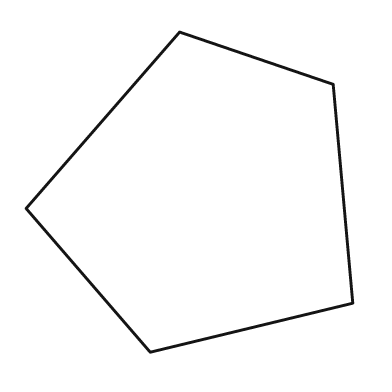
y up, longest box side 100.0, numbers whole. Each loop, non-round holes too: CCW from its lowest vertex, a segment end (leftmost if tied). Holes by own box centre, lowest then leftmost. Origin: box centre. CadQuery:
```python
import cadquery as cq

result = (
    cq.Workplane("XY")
    .moveTo(-12.0, -49.0)
    .lineTo(50.0, -34.0)
    .lineTo(44.0, 33.0)
    .lineTo(-3.0, 49.0)
    .lineTo(-50.0, -5.0)
    .close()
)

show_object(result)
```